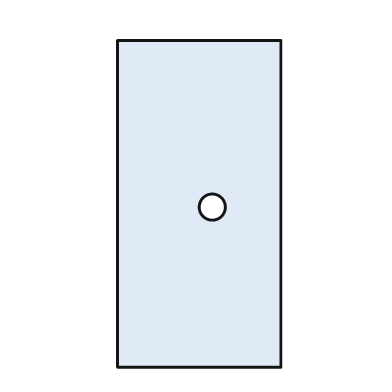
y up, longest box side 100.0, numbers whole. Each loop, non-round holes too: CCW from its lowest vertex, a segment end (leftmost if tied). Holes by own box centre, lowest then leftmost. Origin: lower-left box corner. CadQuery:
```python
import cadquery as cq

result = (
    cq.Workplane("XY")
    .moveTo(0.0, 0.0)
    .lineTo(50.0, 0.0)
    .lineTo(50.0, 100.0)
    .lineTo(0.0, 100.0)
    .close()
    .moveTo(29.0, 49.0)
    .circle(4.0)
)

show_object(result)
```